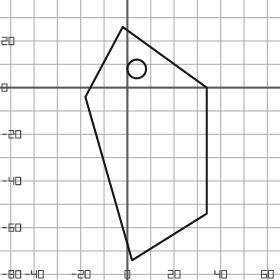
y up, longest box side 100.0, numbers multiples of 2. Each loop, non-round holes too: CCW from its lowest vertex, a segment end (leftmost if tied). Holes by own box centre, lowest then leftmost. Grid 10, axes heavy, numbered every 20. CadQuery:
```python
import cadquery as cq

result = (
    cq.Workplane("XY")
    .moveTo(2.0, -74.0)
    .lineTo(34.0, -54.0)
    .lineTo(34.0, 0.0)
    .lineTo(-2.0, 26.0)
    .lineTo(-18.0, -4.0)
    .close()
    .moveTo(4.0, 8.0)
    .circle(4.0)
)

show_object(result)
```